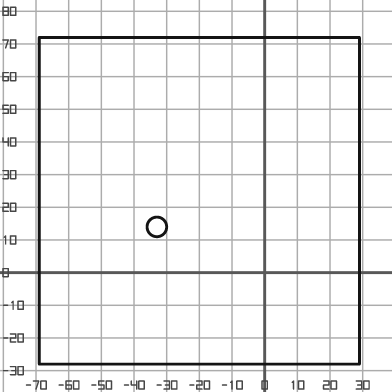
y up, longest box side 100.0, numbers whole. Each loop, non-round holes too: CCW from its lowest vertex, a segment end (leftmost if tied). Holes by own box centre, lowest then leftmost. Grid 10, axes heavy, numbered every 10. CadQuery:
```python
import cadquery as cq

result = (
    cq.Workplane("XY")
    .moveTo(-69.0, -28.0)
    .lineTo(29.0, -28.0)
    .lineTo(29.0, 72.0)
    .lineTo(-69.0, 72.0)
    .close()
    .moveTo(-33.0, 14.0)
    .circle(3.0)
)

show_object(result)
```